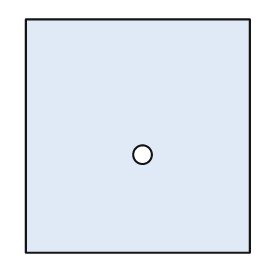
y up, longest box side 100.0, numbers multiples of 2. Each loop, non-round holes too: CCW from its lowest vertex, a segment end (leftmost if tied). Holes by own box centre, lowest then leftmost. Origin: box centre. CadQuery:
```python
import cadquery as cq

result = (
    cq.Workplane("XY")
    .moveTo(-48.0, -50.0)
    .lineTo(48.0, -50.0)
    .lineTo(48.0, 50.0)
    .lineTo(-48.0, 50.0)
    .close()
    .moveTo(2.0, -8.0)
    .circle(4.0)
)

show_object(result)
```